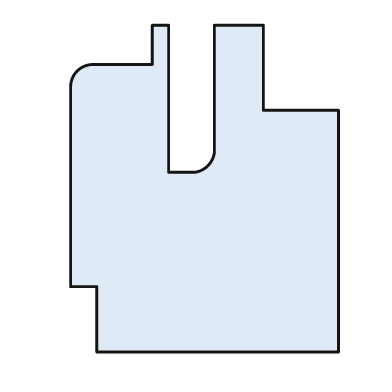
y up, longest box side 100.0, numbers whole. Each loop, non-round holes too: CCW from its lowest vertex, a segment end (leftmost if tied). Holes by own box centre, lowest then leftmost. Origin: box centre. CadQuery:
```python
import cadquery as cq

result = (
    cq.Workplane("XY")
    .moveTo(-33.0, -50.0)
    .lineTo(41.0, -50.0)
    .lineTo(41.0, 24.0)
    .lineTo(18.0, 24.0)
    .lineTo(18.0, 50.0)
    .lineTo(3.0, 50.0)
    .lineTo(3.0, 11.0)
    .threePointArc((1.0, 7.0), (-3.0, 5.0))
    .lineTo(-11.0, 5.0)
    .lineTo(-11.0, 50.0)
    .lineTo(-16.0, 50.0)
    .lineTo(-16.0, 38.0)
    .lineTo(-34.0, 38.0)
    .threePointArc((-39.0, 36.0), (-41.0, 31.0))
    .lineTo(-41.0, -30.0)
    .lineTo(-33.0, -30.0)
    .close()
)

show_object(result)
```